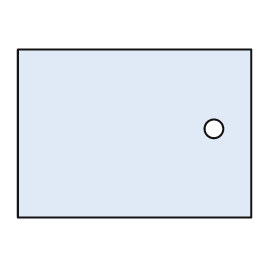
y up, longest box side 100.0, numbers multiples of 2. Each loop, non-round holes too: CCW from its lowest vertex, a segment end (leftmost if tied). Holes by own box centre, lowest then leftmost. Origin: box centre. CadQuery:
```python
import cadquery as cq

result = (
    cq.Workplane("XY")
    .moveTo(-50.0, -36.0)
    .lineTo(50.0, -36.0)
    .lineTo(50.0, 36.0)
    .lineTo(-50.0, 36.0)
    .close()
    .moveTo(34.0, 2.0)
    .circle(4.0)
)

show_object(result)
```